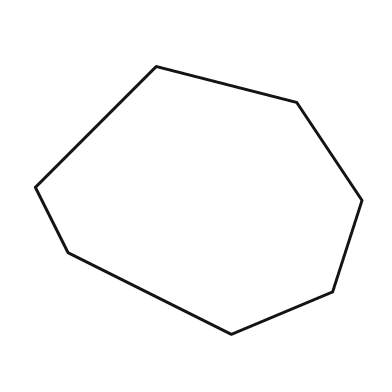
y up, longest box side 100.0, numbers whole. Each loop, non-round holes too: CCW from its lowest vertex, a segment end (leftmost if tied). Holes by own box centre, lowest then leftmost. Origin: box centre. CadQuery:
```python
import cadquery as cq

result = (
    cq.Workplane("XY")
    .moveTo(10.0, -41.0)
    .lineTo(41.0, -28.0)
    .lineTo(50.0, 0.0)
    .lineTo(30.0, 30.0)
    .lineTo(-13.0, 41.0)
    .lineTo(-50.0, 4.0)
    .lineTo(-40.0, -16.0)
    .close()
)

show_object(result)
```